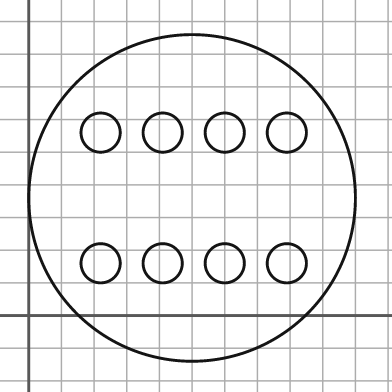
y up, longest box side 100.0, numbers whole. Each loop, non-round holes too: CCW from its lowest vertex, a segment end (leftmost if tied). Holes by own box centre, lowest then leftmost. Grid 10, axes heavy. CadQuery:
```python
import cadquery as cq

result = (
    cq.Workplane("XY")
    .moveTo(50.0, 36.0)
    .circle(50.0)
    .moveTo(22.0, 16.0)
    .circle(6.0)
    .moveTo(41.0, 16.0)
    .circle(6.0)
    .moveTo(60.0, 16.0)
    .circle(6.0)
    .moveTo(79.0, 16.0)
    .circle(6.0)
    .moveTo(22.0, 56.0)
    .circle(6.0)
    .moveTo(41.0, 56.0)
    .circle(6.0)
    .moveTo(60.0, 56.0)
    .circle(6.0)
    .moveTo(79.0, 56.0)
    .circle(6.0)
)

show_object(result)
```